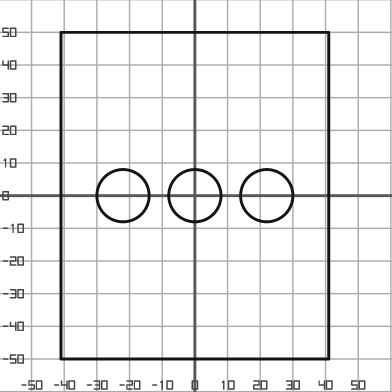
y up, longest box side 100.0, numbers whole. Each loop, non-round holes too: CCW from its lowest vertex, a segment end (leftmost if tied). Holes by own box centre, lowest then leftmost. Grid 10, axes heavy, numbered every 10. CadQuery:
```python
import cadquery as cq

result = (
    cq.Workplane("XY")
    .moveTo(-41.0, -50.0)
    .lineTo(41.0, -50.0)
    .lineTo(41.0, 50.0)
    .lineTo(-41.0, 50.0)
    .close()
    .moveTo(-22.0, 0.0)
    .circle(8.0)
    .moveTo(0.0, 0.0)
    .circle(8.0)
    .moveTo(22.0, 0.0)
    .circle(8.0)
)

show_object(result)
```